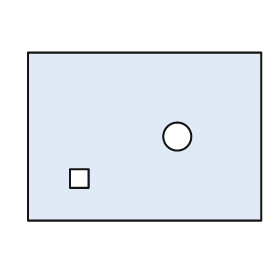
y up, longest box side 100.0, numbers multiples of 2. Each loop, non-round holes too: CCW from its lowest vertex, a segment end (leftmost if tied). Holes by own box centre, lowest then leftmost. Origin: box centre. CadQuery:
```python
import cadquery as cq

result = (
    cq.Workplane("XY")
    .moveTo(-50.0, -36.0)
    .lineTo(50.0, -36.0)
    .lineTo(50.0, 36.0)
    .lineTo(-50.0, 36.0)
    .close()
    .moveTo(-32.0, -22.0)
    .lineTo(-24.0, -22.0)
    .lineTo(-24.0, -14.0)
    .lineTo(-32.0, -14.0)
    .close()
    .moveTo(14.0, 0.0)
    .circle(6.0)
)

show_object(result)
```